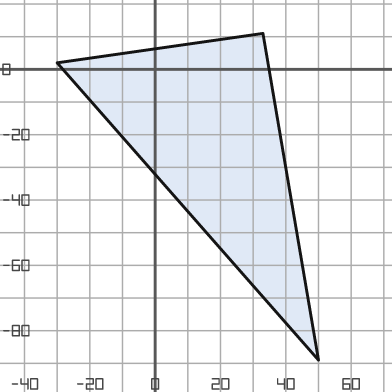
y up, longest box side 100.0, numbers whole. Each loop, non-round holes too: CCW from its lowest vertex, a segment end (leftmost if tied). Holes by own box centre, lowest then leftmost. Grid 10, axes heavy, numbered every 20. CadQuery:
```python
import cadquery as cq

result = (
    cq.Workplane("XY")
    .moveTo(50.0, -89.0)
    .lineTo(33.0, 11.0)
    .lineTo(-30.0, 2.0)
    .close()
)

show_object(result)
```